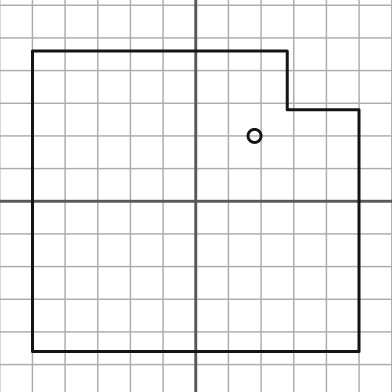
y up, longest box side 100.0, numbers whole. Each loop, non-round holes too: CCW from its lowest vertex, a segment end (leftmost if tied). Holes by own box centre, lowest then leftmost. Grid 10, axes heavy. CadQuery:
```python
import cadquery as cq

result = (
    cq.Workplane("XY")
    .moveTo(-50.0, -46.0)
    .lineTo(50.0, -46.0)
    .lineTo(50.0, 28.0)
    .lineTo(28.0, 28.0)
    .lineTo(28.0, 46.0)
    .lineTo(-50.0, 46.0)
    .close()
    .moveTo(18.0, 20.0)
    .circle(2.0)
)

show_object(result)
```